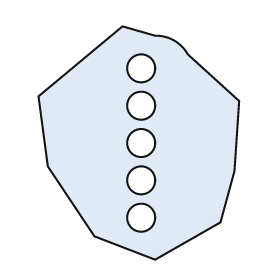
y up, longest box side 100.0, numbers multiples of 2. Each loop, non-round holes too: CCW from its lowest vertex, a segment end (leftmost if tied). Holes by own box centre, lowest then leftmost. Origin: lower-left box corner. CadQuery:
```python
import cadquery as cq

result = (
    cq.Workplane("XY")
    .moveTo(50.0, 0.0)
    .lineTo(78.0, 16.0)
    .lineTo(84.0, 38.0)
    .lineTo(86.0, 68.0)
    .lineTo(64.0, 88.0)
    .threePointArc((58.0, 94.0), (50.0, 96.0))
    .lineTo(36.0, 100.0)
    .lineTo(0.0, 70.0)
    .lineTo(4.0, 40.0)
    .lineTo(24.0, 10.0)
    .close()
    .moveTo(44.0, 18.0)
    .circle(6.0)
    .moveTo(44.0, 34.0)
    .circle(6.0)
    .moveTo(44.0, 50.0)
    .circle(6.0)
    .moveTo(44.0, 66.0)
    .circle(6.0)
    .moveTo(44.0, 82.0)
    .circle(6.0)
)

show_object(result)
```